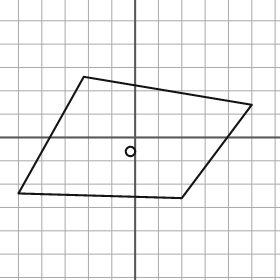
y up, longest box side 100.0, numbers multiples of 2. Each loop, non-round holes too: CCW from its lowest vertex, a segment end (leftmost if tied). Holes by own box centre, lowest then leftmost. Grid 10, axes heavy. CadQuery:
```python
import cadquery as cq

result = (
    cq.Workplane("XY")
    .moveTo(20.0, -26.0)
    .lineTo(50.0, 14.0)
    .lineTo(-22.0, 26.0)
    .lineTo(-50.0, -24.0)
    .close()
    .moveTo(-2.0, -6.0)
    .circle(2.0)
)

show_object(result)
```